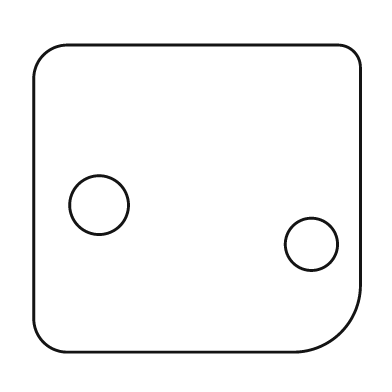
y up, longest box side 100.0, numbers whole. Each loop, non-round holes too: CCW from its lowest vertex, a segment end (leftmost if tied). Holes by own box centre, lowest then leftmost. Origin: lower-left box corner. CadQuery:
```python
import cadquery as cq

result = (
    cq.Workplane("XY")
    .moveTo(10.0, 0.0)
    .lineTo(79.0, 0.0)
    .threePointArc((94.0, 6.0), (100.0, 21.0))
    .lineTo(100.0, 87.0)
    .threePointArc((98.0, 92.0), (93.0, 94.0))
    .lineTo(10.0, 94.0)
    .threePointArc((3.0, 91.0), (0.0, 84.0))
    .lineTo(0.0, 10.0)
    .threePointArc((3.0, 3.0), (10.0, 0.0))
    .close()
    .moveTo(85.0, 33.0)
    .circle(8.0)
    .moveTo(20.0, 45.0)
    .circle(9.0)
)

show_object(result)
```